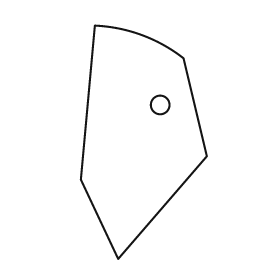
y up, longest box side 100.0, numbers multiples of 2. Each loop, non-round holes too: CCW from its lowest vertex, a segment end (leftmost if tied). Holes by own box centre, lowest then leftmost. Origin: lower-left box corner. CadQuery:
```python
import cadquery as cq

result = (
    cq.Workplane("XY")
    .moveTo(16.0, 0.0)
    .lineTo(54.0, 44.0)
    .lineTo(44.0, 86.0)
    .threePointArc((26.0, 96.0), (6.0, 100.0))
    .lineTo(0.0, 34.0)
    .close()
    .moveTo(34.0, 66.0)
    .circle(4.0)
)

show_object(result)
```